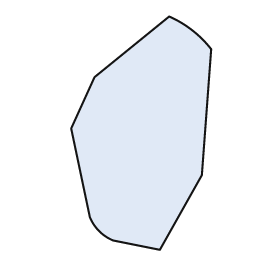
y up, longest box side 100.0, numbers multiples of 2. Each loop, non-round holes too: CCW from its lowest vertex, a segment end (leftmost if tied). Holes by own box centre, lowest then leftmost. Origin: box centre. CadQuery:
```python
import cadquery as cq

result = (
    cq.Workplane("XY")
    .moveTo(8.0, -50.0)
    .lineTo(26.0, -18.0)
    .lineTo(30.0, 36.0)
    .threePointArc((22.0, 44.0), (12.0, 50.0))
    .lineTo(-20.0, 24.0)
    .lineTo(-30.0, 2.0)
    .lineTo(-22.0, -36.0)
    .threePointArc((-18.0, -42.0), (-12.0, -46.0))
    .close()
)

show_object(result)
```